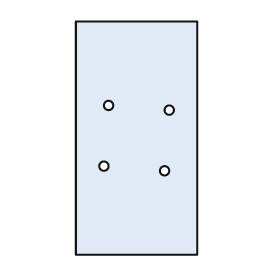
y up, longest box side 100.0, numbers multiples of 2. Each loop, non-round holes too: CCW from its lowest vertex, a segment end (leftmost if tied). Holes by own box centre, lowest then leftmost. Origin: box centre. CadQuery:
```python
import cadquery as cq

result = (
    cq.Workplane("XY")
    .moveTo(-26.0, -50.0)
    .lineTo(26.0, -50.0)
    .lineTo(26.0, 50.0)
    .lineTo(-26.0, 50.0)
    .close()
    .moveTo(12.0, -14.0)
    .circle(2.0)
    .moveTo(-14.0, -12.0)
    .circle(2.0)
    .moveTo(14.0, 12.0)
    .circle(2.0)
    .moveTo(-12.0, 14.0)
    .circle(2.0)
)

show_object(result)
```